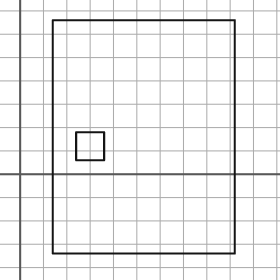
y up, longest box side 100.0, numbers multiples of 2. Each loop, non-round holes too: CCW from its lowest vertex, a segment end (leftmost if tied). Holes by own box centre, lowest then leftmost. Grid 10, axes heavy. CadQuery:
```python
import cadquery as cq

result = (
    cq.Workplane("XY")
    .moveTo(14.0, -34.0)
    .lineTo(92.0, -34.0)
    .lineTo(92.0, 66.0)
    .lineTo(14.0, 66.0)
    .close()
    .moveTo(24.0, 6.0)
    .lineTo(36.0, 6.0)
    .lineTo(36.0, 18.0)
    .lineTo(24.0, 18.0)
    .close()
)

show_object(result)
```